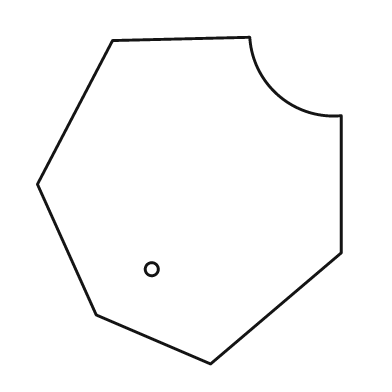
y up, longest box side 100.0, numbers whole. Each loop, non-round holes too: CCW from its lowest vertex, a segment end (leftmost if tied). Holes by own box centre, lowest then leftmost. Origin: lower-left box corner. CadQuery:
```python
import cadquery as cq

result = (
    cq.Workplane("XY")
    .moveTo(53.0, 0.0)
    .lineTo(93.0, 34.0)
    .lineTo(93.0, 76.0)
    .threePointArc((74.0, 82.0), (65.0, 100.0))
    .lineTo(23.0, 99.0)
    .lineTo(0.0, 55.0)
    .lineTo(18.0, 15.0)
    .close()
    .moveTo(35.0, 29.0)
    .circle(2.0)
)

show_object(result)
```